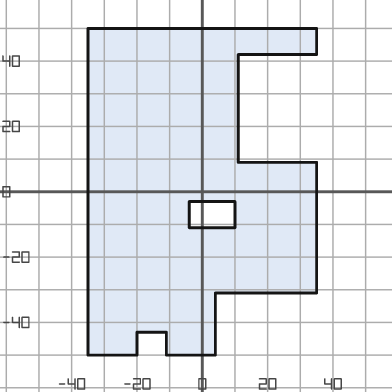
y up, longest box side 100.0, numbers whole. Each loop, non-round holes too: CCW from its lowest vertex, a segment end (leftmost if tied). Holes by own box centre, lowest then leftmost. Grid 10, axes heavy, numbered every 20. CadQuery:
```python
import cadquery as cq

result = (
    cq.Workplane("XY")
    .moveTo(-35.0, -50.0)
    .lineTo(-20.0, -50.0)
    .lineTo(-20.0, -43.0)
    .lineTo(-11.0, -43.0)
    .lineTo(-11.0, -50.0)
    .lineTo(4.0, -50.0)
    .lineTo(4.0, -31.0)
    .lineTo(35.0, -31.0)
    .lineTo(35.0, 9.0)
    .lineTo(11.0, 9.0)
    .lineTo(11.0, 42.0)
    .lineTo(35.0, 42.0)
    .lineTo(35.0, 50.0)
    .lineTo(-35.0, 50.0)
    .close()
    .moveTo(-4.0, -11.0)
    .lineTo(10.0, -11.0)
    .lineTo(10.0, -3.0)
    .lineTo(-4.0, -3.0)
    .close()
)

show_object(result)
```